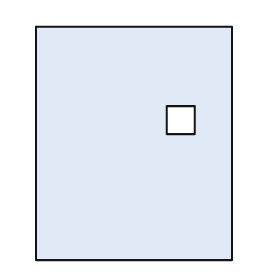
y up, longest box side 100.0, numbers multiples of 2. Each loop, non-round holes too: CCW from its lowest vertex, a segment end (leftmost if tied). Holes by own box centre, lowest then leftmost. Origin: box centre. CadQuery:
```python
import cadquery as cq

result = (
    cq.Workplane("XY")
    .moveTo(-42.0, -50.0)
    .lineTo(42.0, -50.0)
    .lineTo(42.0, 50.0)
    .lineTo(-42.0, 50.0)
    .close()
    .moveTo(14.0, 4.0)
    .lineTo(26.0, 4.0)
    .lineTo(26.0, 16.0)
    .lineTo(14.0, 16.0)
    .close()
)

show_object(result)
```